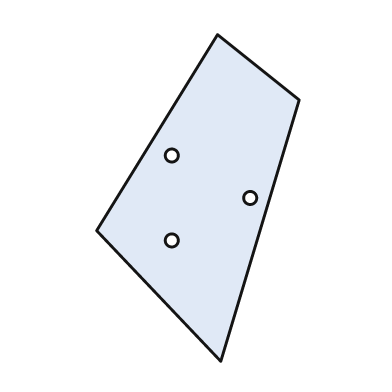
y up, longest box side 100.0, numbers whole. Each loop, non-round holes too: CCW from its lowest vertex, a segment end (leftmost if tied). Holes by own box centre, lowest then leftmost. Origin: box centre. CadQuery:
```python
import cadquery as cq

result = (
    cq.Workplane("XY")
    .moveTo(7.0, -50.0)
    .lineTo(31.0, 30.0)
    .lineTo(6.0, 50.0)
    .lineTo(-31.0, -10.0)
    .close()
    .moveTo(-8.0, -13.0)
    .circle(2.0)
    .moveTo(16.0, 0.0)
    .circle(2.0)
    .moveTo(-8.0, 13.0)
    .circle(2.0)
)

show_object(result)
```